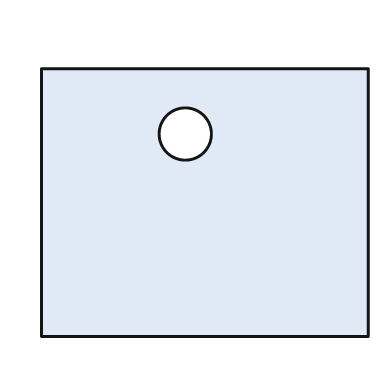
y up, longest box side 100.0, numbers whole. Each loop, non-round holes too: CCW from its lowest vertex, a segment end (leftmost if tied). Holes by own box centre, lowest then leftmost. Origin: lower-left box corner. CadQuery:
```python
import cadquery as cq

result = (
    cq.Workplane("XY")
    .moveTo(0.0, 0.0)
    .lineTo(100.0, 0.0)
    .lineTo(100.0, 82.0)
    .lineTo(0.0, 82.0)
    .close()
    .moveTo(44.0, 62.0)
    .circle(8.0)
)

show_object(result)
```